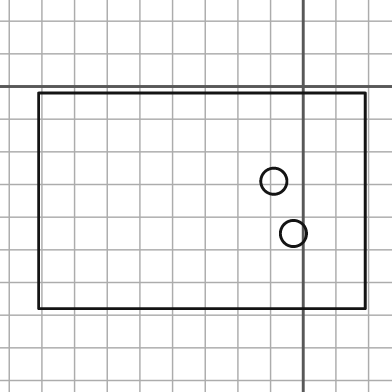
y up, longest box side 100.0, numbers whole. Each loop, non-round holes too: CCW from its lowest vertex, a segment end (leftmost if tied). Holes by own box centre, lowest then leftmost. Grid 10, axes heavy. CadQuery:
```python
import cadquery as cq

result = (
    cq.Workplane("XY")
    .moveTo(-81.0, -68.0)
    .lineTo(19.0, -68.0)
    .lineTo(19.0, -2.0)
    .lineTo(-81.0, -2.0)
    .close()
    .moveTo(-3.0, -45.0)
    .circle(4.0)
    .moveTo(-9.0, -29.0)
    .circle(4.0)
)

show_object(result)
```